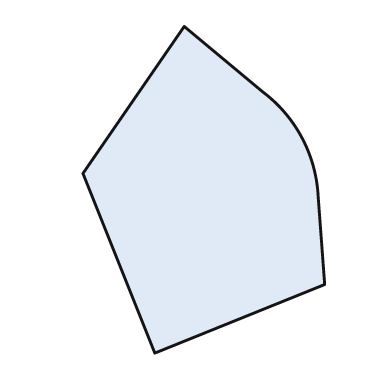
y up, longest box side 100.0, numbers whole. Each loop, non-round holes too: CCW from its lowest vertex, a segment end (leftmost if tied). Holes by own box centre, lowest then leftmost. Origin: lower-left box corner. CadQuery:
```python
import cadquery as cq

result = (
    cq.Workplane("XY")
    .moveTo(22.0, 0.0)
    .lineTo(74.0, 21.0)
    .lineTo(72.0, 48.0)
    .threePointArc((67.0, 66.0), (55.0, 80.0))
    .lineTo(31.0, 100.0)
    .lineTo(0.0, 55.0)
    .close()
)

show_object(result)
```